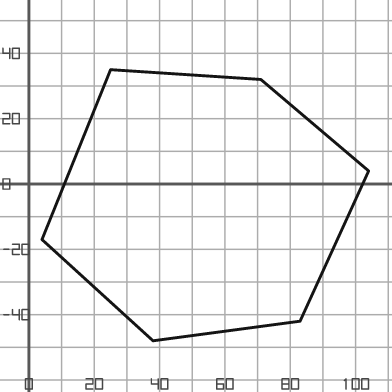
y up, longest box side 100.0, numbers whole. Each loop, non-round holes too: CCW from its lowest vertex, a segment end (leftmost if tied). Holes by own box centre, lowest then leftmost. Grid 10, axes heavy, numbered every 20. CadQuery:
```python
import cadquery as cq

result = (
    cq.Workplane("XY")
    .moveTo(38.0, -48.0)
    .lineTo(83.0, -42.0)
    .lineTo(104.0, 4.0)
    .lineTo(71.0, 32.0)
    .lineTo(25.0, 35.0)
    .lineTo(4.0, -17.0)
    .close()
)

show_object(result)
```